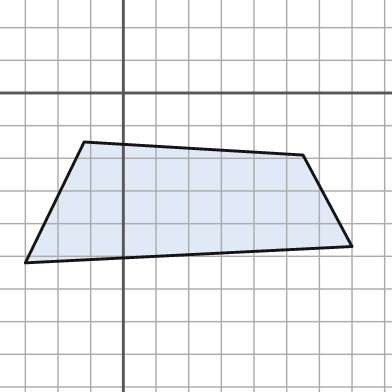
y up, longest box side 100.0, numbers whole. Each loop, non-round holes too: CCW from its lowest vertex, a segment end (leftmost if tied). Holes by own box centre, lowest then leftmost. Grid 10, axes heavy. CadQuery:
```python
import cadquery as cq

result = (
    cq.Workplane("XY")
    .moveTo(-30.0, -52.0)
    .lineTo(70.0, -47.0)
    .lineTo(55.0, -19.0)
    .lineTo(-12.0, -15.0)
    .close()
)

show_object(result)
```